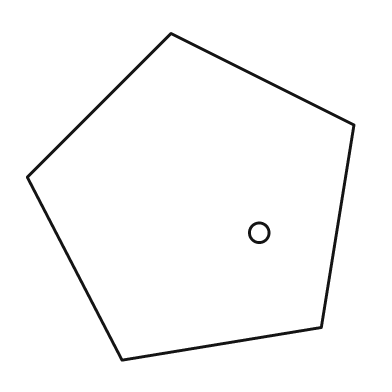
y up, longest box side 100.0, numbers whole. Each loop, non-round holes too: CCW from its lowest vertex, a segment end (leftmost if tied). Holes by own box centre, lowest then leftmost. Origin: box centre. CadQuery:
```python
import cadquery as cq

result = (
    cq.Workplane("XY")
    .moveTo(-21.0, -50.0)
    .lineTo(40.0, -40.0)
    .lineTo(50.0, 22.0)
    .lineTo(-6.0, 50.0)
    .lineTo(-50.0, 6.0)
    .close()
    .moveTo(21.0, -11.0)
    .circle(3.0)
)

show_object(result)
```